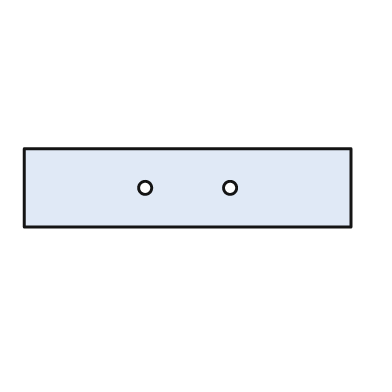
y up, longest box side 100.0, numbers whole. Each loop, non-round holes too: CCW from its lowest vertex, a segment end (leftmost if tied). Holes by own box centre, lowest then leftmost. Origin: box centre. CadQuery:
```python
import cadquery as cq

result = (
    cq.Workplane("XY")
    .moveTo(-50.0, -12.0)
    .lineTo(50.0, -12.0)
    .lineTo(50.0, 12.0)
    .lineTo(-50.0, 12.0)
    .close()
    .moveTo(-13.0, 0.0)
    .circle(2.0)
    .moveTo(13.0, 0.0)
    .circle(2.0)
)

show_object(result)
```